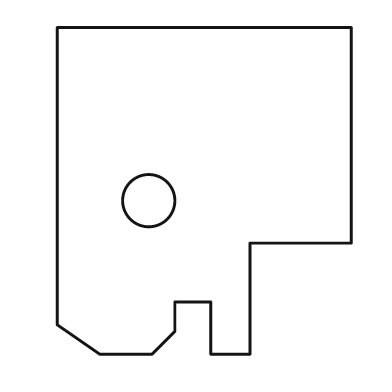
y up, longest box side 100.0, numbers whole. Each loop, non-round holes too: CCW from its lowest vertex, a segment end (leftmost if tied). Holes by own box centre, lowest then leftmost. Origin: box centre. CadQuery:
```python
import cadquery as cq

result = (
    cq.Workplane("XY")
    .moveTo(-32.0, -50.0)
    .lineTo(-16.0, -50.0)
    .lineTo(-9.0, -43.0)
    .lineTo(-9.0, -34.0)
    .lineTo(2.0, -34.0)
    .lineTo(2.0, -50.0)
    .lineTo(14.0, -50.0)
    .lineTo(14.0, -16.0)
    .lineTo(45.0, -16.0)
    .lineTo(45.0, 50.0)
    .lineTo(-45.0, 50.0)
    .lineTo(-45.0, -41.0)
    .close()
    .moveTo(-17.0, -3.0)
    .circle(8.0)
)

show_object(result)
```